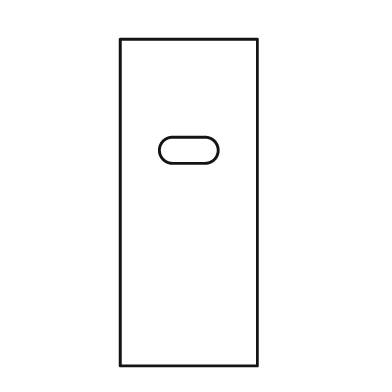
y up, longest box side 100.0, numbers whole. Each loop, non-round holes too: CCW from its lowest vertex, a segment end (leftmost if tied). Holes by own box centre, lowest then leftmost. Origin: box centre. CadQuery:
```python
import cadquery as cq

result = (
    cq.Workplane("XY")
    .moveTo(-21.0, -50.0)
    .lineTo(21.0, -50.0)
    .lineTo(21.0, 50.0)
    .lineTo(-21.0, 50.0)
    .close()
    .moveTo(-5.0, 12.0)
    .lineTo(5.0, 12.0)
    .threePointArc((9.0, 16.0), (5.0, 20.0))
    .lineTo(-5.0, 20.0)
    .threePointArc((-9.0, 16.0), (-5.0, 12.0))
    .close()
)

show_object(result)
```